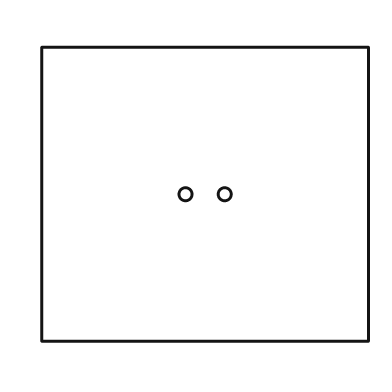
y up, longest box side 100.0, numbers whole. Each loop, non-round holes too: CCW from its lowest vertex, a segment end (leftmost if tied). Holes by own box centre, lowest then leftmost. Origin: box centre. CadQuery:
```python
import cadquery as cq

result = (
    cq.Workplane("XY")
    .moveTo(-50.0, -45.0)
    .lineTo(50.0, -45.0)
    .lineTo(50.0, 45.0)
    .lineTo(-50.0, 45.0)
    .close()
    .moveTo(-6.0, 0.0)
    .circle(2.0)
    .moveTo(6.0, 0.0)
    .circle(2.0)
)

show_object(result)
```